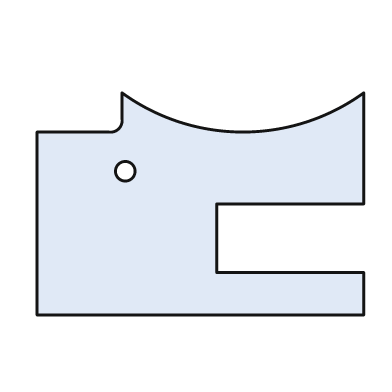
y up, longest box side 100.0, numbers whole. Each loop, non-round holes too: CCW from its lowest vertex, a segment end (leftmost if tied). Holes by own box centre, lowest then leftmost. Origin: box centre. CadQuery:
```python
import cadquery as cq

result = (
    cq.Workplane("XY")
    .moveTo(-50.0, -34.0)
    .lineTo(50.0, -34.0)
    .lineTo(50.0, -21.0)
    .lineTo(5.0, -21.0)
    .lineTo(5.0, 0.0)
    .lineTo(50.0, 0.0)
    .lineTo(50.0, 34.0)
    .threePointArc((13.0, 22.0), (-24.0, 34.0))
    .lineTo(-24.0, 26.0)
    .threePointArc((-25.0, 23.0), (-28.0, 22.0))
    .lineTo(-50.0, 22.0)
    .close()
    .moveTo(-23.0, 10.0)
    .circle(3.0)
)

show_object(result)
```